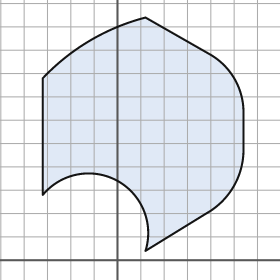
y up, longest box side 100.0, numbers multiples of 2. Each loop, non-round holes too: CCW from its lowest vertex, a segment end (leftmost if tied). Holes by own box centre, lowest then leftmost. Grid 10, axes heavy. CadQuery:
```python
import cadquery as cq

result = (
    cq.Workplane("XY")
    .moveTo(12.0, 4.0)
    .lineTo(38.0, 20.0)
    .threePointArc((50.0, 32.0), (54.0, 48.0))
    .lineTo(54.0, 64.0)
    .threePointArc((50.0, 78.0), (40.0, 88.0))
    .lineTo(12.0, 104.0)
    .threePointArc((-12.0, 94.0), (-32.0, 78.0))
    .lineTo(-32.0, 28.0)
    .threePointArc((0.0, 34.0), (12.0, 4.0))
    .close()
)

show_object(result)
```